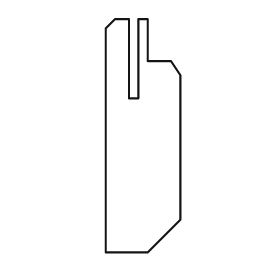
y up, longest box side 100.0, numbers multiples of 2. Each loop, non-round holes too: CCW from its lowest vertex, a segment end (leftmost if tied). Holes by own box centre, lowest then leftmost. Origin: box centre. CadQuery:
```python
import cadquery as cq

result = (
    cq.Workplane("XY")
    .moveTo(-16.0, -50.0)
    .lineTo(2.0, -50.0)
    .lineTo(16.0, -36.0)
    .lineTo(16.0, 26.0)
    .lineTo(12.0, 32.0)
    .lineTo(2.0, 32.0)
    .lineTo(2.0, 50.0)
    .lineTo(-2.0, 50.0)
    .lineTo(-2.0, 16.0)
    .lineTo(-6.0, 16.0)
    .lineTo(-6.0, 50.0)
    .lineTo(-12.0, 50.0)
    .lineTo(-16.0, 46.0)
    .close()
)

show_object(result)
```